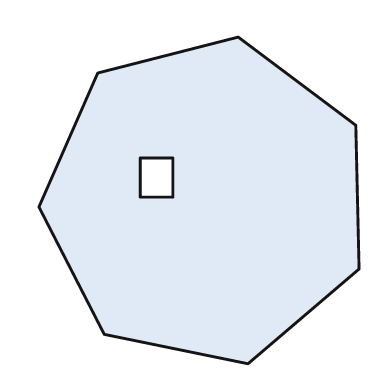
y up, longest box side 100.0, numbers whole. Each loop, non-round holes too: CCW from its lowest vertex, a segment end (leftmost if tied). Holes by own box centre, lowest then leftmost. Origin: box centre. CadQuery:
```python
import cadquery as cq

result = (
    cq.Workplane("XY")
    .moveTo(15.0, -50.0)
    .lineTo(49.0, -21.0)
    .lineTo(48.0, 23.0)
    .lineTo(12.0, 50.0)
    .lineTo(-31.0, 39.0)
    .lineTo(-49.0, -2.0)
    .lineTo(-29.0, -41.0)
    .close()
    .moveTo(-18.0, 1.0)
    .lineTo(-8.0, 1.0)
    .lineTo(-8.0, 13.0)
    .lineTo(-18.0, 13.0)
    .close()
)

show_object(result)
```